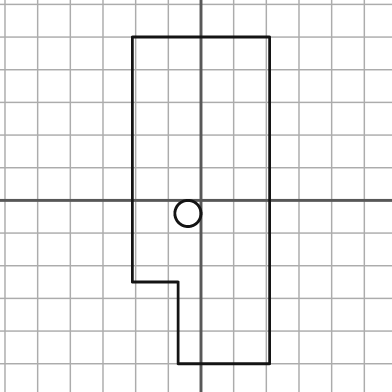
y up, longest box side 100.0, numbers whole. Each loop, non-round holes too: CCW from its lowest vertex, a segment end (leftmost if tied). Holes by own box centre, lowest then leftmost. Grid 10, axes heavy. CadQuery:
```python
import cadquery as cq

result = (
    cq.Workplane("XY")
    .moveTo(-7.0, -50.0)
    .lineTo(21.0, -50.0)
    .lineTo(21.0, 50.0)
    .lineTo(-21.0, 50.0)
    .lineTo(-21.0, -25.0)
    .lineTo(-7.0, -25.0)
    .close()
    .moveTo(-4.0, -4.0)
    .circle(4.0)
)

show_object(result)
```